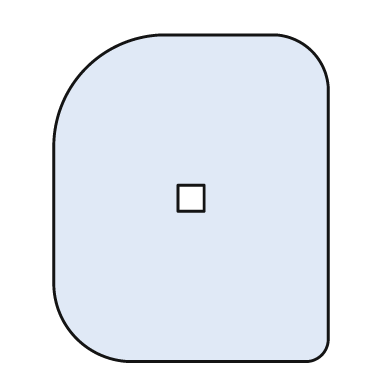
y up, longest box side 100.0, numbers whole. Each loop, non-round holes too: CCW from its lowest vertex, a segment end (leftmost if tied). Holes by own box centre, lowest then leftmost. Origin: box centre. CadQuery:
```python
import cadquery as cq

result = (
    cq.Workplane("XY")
    .moveTo(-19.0, -50.0)
    .lineTo(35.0, -50.0)
    .threePointArc((40.0, -48.0), (42.0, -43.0))
    .lineTo(42.0, 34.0)
    .threePointArc((37.0, 45.0), (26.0, 50.0))
    .lineTo(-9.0, 50.0)
    .threePointArc((-32.0, 40.0), (-42.0, 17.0))
    .lineTo(-42.0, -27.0)
    .threePointArc((-35.0, -43.0), (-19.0, -50.0))
    .close()
    .moveTo(-4.0, -4.0)
    .lineTo(4.0, -4.0)
    .lineTo(4.0, 4.0)
    .lineTo(-4.0, 4.0)
    .close()
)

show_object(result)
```